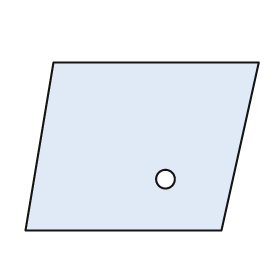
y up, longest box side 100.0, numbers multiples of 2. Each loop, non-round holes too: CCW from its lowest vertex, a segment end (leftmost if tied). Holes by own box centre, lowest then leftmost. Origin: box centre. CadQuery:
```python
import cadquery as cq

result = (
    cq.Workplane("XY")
    .moveTo(-50.0, -36.0)
    .lineTo(34.0, -36.0)
    .lineTo(50.0, 36.0)
    .lineTo(-38.0, 36.0)
    .close()
    .moveTo(10.0, -14.0)
    .circle(4.0)
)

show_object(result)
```